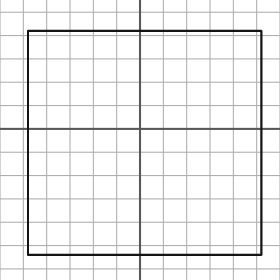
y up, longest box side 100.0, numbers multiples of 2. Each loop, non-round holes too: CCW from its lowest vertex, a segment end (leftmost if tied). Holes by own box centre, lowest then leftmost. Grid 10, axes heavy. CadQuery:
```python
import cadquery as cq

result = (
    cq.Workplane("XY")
    .moveTo(-48.0, -54.0)
    .lineTo(52.0, -54.0)
    .lineTo(52.0, 42.0)
    .lineTo(-48.0, 42.0)
    .close()
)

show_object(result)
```